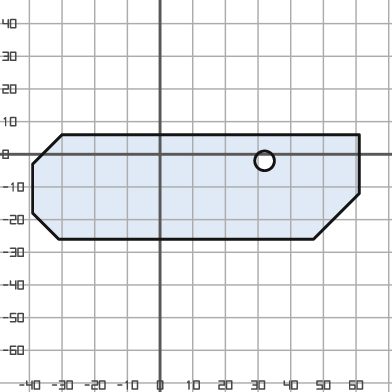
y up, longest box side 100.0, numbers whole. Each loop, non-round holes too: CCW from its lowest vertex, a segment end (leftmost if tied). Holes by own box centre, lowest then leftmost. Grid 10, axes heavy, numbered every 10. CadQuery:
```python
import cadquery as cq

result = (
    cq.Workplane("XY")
    .moveTo(-31.0, -26.0)
    .lineTo(47.0, -26.0)
    .lineTo(61.0, -12.0)
    .lineTo(61.0, 6.0)
    .lineTo(-30.0, 6.0)
    .lineTo(-39.0, -3.0)
    .lineTo(-39.0, -18.0)
    .close()
    .moveTo(32.0, -2.0)
    .circle(3.0)
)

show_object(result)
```